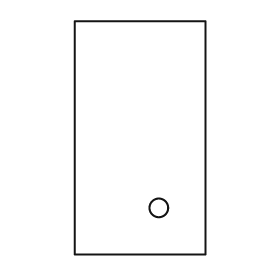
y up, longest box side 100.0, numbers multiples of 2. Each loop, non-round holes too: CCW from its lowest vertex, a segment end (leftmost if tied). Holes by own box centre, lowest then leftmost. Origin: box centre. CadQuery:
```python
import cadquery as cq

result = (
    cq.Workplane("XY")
    .moveTo(-28.0, -50.0)
    .lineTo(28.0, -50.0)
    .lineTo(28.0, 50.0)
    .lineTo(-28.0, 50.0)
    .close()
    .moveTo(8.0, -30.0)
    .circle(4.0)
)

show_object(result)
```